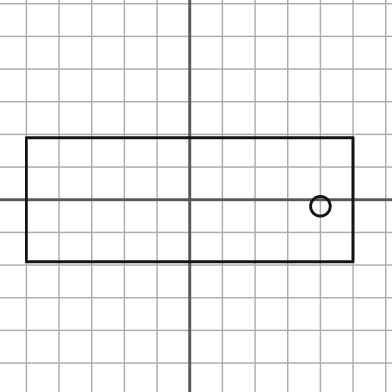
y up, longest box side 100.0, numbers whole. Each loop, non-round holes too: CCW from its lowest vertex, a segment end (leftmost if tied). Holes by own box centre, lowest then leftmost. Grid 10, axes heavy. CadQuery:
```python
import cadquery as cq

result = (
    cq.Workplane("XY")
    .moveTo(-50.0, -19.0)
    .lineTo(50.0, -19.0)
    .lineTo(50.0, 19.0)
    .lineTo(-50.0, 19.0)
    .close()
    .moveTo(40.0, -2.0)
    .circle(3.0)
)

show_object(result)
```